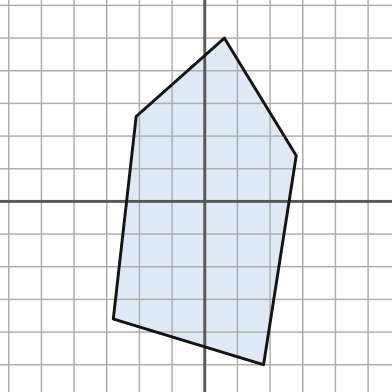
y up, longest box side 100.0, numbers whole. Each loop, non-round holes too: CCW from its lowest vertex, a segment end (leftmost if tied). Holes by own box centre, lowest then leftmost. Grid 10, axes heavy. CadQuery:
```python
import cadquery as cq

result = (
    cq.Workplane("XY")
    .moveTo(18.0, -50.0)
    .lineTo(28.0, 14.0)
    .lineTo(6.0, 50.0)
    .lineTo(-21.0, 26.0)
    .lineTo(-28.0, -36.0)
    .close()
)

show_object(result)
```